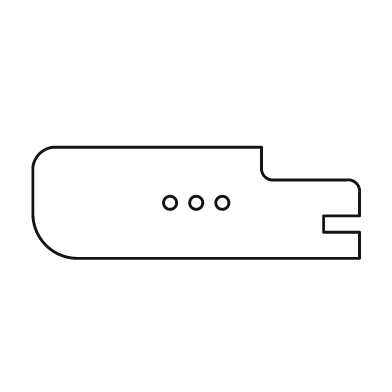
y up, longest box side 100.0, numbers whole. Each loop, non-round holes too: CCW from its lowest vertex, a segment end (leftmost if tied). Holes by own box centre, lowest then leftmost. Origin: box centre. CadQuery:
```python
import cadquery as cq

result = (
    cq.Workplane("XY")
    .moveTo(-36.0, -17.0)
    .lineTo(50.0, -17.0)
    .lineTo(50.0, -9.0)
    .lineTo(39.0, -9.0)
    .lineTo(39.0, -4.0)
    .lineTo(50.0, -4.0)
    .lineTo(50.0, 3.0)
    .threePointArc((49.0, 6.0), (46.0, 7.0))
    .lineTo(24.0, 7.0)
    .threePointArc((21.0, 8.0), (20.0, 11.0))
    .lineTo(20.0, 17.0)
    .lineTo(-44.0, 17.0)
    .threePointArc((-48.0, 15.0), (-50.0, 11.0))
    .lineTo(-50.0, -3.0)
    .threePointArc((-46.0, -13.0), (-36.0, -17.0))
    .close()
    .moveTo(-8.0, 0.0)
    .circle(2.0)
    .moveTo(0.0, 0.0)
    .circle(2.0)
    .moveTo(8.0, 0.0)
    .circle(2.0)
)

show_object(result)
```